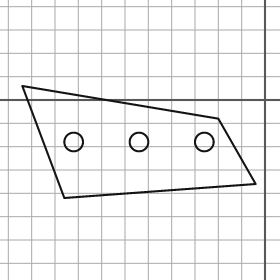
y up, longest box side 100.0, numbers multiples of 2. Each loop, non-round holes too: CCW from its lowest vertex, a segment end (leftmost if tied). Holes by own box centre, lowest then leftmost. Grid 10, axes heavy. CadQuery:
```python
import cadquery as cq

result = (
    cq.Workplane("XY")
    .moveTo(-86.0, -42.0)
    .lineTo(-4.0, -36.0)
    .lineTo(-20.0, -8.0)
    .lineTo(-104.0, 6.0)
    .close()
    .moveTo(-82.0, -18.0)
    .circle(4.0)
    .moveTo(-54.0, -18.0)
    .circle(4.0)
    .moveTo(-26.0, -18.0)
    .circle(4.0)
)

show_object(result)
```